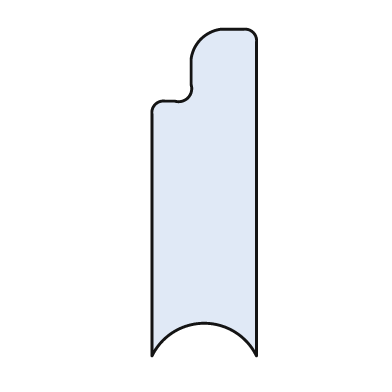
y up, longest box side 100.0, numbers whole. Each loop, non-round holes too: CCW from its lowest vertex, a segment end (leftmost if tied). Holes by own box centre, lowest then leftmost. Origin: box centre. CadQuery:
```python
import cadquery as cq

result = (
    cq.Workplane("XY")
    .moveTo(-16.0, -50.0)
    .threePointArc((0.0, -40.0), (16.0, -50.0))
    .lineTo(16.0, 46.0)
    .threePointArc((15.0, 49.0), (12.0, 50.0))
    .lineTo(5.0, 50.0)
    .threePointArc((-1.0, 47.0), (-4.0, 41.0))
    .lineTo(-4.0, 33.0)
    .threePointArc((-5.0, 29.0), (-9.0, 28.0))
    .lineTo(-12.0, 28.0)
    .threePointArc((-15.0, 27.0), (-16.0, 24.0))
    .close()
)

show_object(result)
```